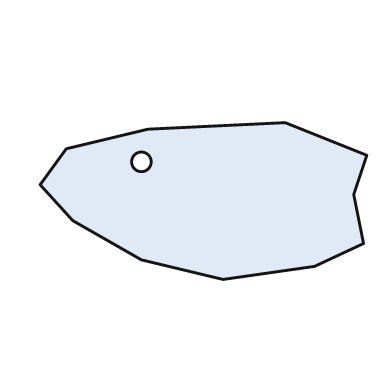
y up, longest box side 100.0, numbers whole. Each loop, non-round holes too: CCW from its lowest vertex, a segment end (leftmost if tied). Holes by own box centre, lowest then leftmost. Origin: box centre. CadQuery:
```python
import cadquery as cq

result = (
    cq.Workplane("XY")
    .moveTo(6.0, -24.0)
    .lineTo(34.0, -20.0)
    .lineTo(49.0, -13.0)
    .lineTo(46.0, 2.0)
    .lineTo(50.0, 14.0)
    .lineTo(25.0, 24.0)
    .lineTo(-17.0, 22.0)
    .lineTo(-42.0, 16.0)
    .lineTo(-50.0, 5.0)
    .lineTo(-40.0, -6.0)
    .lineTo(-19.0, -18.0)
    .close()
    .moveTo(-19.0, 12.0)
    .circle(3.0)
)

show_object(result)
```